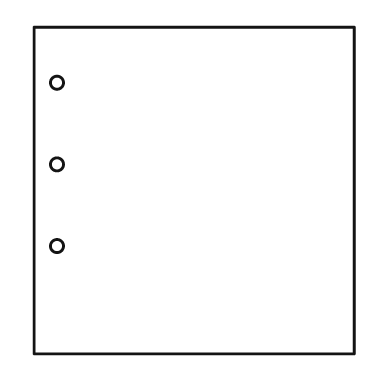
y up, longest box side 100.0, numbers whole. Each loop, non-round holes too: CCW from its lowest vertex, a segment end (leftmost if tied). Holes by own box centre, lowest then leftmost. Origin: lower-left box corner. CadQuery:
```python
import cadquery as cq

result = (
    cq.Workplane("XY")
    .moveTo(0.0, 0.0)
    .lineTo(98.0, 0.0)
    .lineTo(98.0, 100.0)
    .lineTo(0.0, 100.0)
    .close()
    .moveTo(7.0, 33.0)
    .circle(2.0)
    .moveTo(7.0, 58.0)
    .circle(2.0)
    .moveTo(7.0, 83.0)
    .circle(2.0)
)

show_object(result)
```